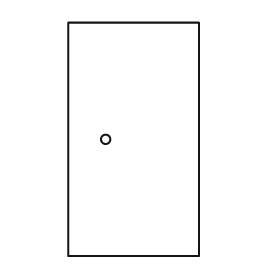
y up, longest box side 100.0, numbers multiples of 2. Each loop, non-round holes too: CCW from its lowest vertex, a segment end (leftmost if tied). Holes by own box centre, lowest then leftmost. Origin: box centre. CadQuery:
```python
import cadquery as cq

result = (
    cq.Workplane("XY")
    .moveTo(-28.0, -50.0)
    .lineTo(28.0, -50.0)
    .lineTo(28.0, 50.0)
    .lineTo(-28.0, 50.0)
    .close()
    .moveTo(-12.0, 0.0)
    .circle(2.0)
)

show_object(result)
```